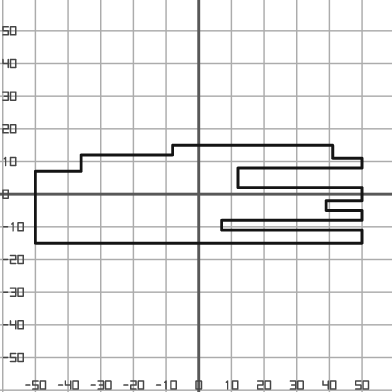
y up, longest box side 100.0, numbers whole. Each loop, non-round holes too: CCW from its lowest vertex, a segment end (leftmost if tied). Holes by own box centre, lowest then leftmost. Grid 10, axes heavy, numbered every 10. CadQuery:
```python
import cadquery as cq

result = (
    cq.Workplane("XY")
    .moveTo(-50.0, -15.0)
    .lineTo(50.0, -15.0)
    .lineTo(50.0, -11.0)
    .lineTo(7.0, -11.0)
    .lineTo(7.0, -8.0)
    .lineTo(50.0, -8.0)
    .lineTo(50.0, -5.0)
    .lineTo(39.0, -5.0)
    .lineTo(39.0, -2.0)
    .lineTo(50.0, -2.0)
    .lineTo(50.0, 2.0)
    .lineTo(12.0, 2.0)
    .lineTo(12.0, 8.0)
    .lineTo(50.0, 8.0)
    .lineTo(50.0, 11.0)
    .lineTo(41.0, 11.0)
    .lineTo(41.0, 15.0)
    .lineTo(-8.0, 15.0)
    .lineTo(-8.0, 12.0)
    .lineTo(-36.0, 12.0)
    .lineTo(-36.0, 7.0)
    .lineTo(-50.0, 7.0)
    .close()
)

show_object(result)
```